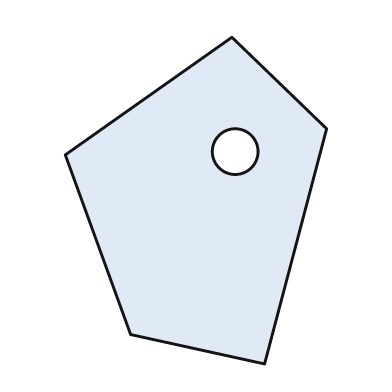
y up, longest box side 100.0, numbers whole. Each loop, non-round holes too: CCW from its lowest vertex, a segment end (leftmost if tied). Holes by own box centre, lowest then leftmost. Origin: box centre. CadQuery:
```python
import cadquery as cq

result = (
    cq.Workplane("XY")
    .moveTo(21.0, -50.0)
    .lineTo(40.0, 22.0)
    .lineTo(11.0, 50.0)
    .lineTo(-40.0, 14.0)
    .lineTo(-20.0, -41.0)
    .close()
    .moveTo(12.0, 15.0)
    .circle(7.0)
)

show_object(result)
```